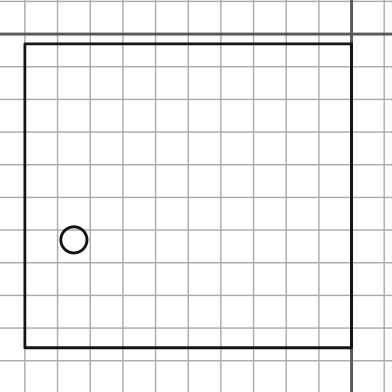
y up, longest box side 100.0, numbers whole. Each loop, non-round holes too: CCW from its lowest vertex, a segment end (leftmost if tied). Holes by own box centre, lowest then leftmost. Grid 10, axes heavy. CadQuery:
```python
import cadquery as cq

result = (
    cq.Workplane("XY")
    .moveTo(-100.0, -96.0)
    .lineTo(0.0, -96.0)
    .lineTo(0.0, -3.0)
    .lineTo(-100.0, -3.0)
    .close()
    .moveTo(-85.0, -63.0)
    .circle(4.0)
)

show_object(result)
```